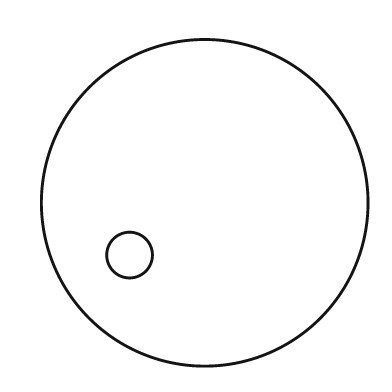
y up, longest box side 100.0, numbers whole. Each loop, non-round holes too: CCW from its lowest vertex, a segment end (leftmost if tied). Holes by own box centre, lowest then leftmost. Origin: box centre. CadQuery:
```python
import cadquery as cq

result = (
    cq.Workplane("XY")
    .moveTo(0.0, 0.0)
    .circle(50.0)
    .moveTo(-23.0, -16.0)
    .circle(7.0)
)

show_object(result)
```